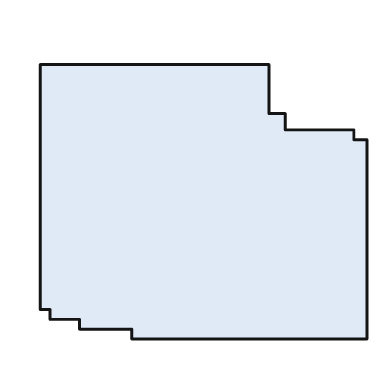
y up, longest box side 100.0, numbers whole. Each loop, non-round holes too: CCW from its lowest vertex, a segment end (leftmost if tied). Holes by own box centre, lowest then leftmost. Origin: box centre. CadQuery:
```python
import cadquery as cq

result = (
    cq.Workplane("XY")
    .moveTo(-22.0, -42.0)
    .lineTo(50.0, -42.0)
    .lineTo(50.0, 19.0)
    .lineTo(46.0, 19.0)
    .lineTo(46.0, 22.0)
    .lineTo(25.0, 22.0)
    .lineTo(25.0, 27.0)
    .lineTo(20.0, 27.0)
    .lineTo(20.0, 42.0)
    .lineTo(-50.0, 42.0)
    .lineTo(-50.0, -33.0)
    .lineTo(-47.0, -33.0)
    .lineTo(-47.0, -36.0)
    .lineTo(-38.0, -36.0)
    .lineTo(-38.0, -39.0)
    .lineTo(-22.0, -39.0)
    .close()
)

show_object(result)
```